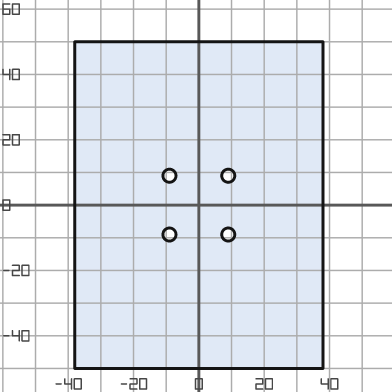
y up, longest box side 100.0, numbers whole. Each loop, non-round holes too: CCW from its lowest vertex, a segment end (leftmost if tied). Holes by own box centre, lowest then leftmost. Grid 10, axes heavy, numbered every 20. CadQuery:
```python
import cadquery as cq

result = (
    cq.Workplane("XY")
    .moveTo(-38.0, -50.0)
    .lineTo(38.0, -50.0)
    .lineTo(38.0, 50.0)
    .lineTo(-38.0, 50.0)
    .close()
    .moveTo(-9.0, -9.0)
    .circle(2.0)
    .moveTo(9.0, -9.0)
    .circle(2.0)
    .moveTo(-9.0, 9.0)
    .circle(2.0)
    .moveTo(9.0, 9.0)
    .circle(2.0)
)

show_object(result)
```